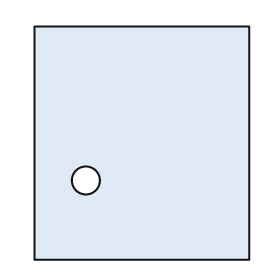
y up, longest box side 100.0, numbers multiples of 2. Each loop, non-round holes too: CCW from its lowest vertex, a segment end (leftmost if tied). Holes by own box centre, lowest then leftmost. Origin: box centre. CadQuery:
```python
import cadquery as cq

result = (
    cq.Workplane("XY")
    .moveTo(-46.0, -50.0)
    .lineTo(46.0, -50.0)
    .lineTo(46.0, 50.0)
    .lineTo(-46.0, 50.0)
    .close()
    .moveTo(-24.0, -16.0)
    .circle(6.0)
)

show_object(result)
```